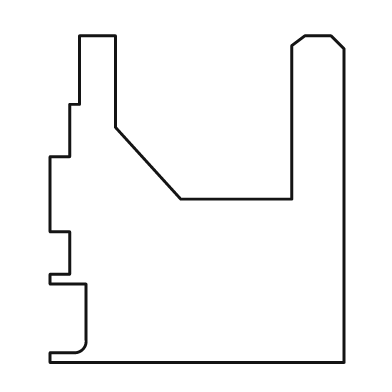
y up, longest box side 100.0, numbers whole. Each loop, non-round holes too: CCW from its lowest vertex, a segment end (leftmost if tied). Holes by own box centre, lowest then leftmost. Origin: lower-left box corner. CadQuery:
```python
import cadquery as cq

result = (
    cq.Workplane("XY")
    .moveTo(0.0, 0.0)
    .lineTo(90.0, 0.0)
    .lineTo(90.0, 96.0)
    .lineTo(86.0, 100.0)
    .lineTo(78.0, 100.0)
    .lineTo(74.0, 97.0)
    .lineTo(74.0, 50.0)
    .lineTo(40.0, 50.0)
    .lineTo(20.0, 72.0)
    .lineTo(20.0, 100.0)
    .lineTo(9.0, 100.0)
    .lineTo(9.0, 79.0)
    .lineTo(6.0, 79.0)
    .lineTo(6.0, 63.0)
    .lineTo(0.0, 63.0)
    .lineTo(0.0, 40.0)
    .lineTo(6.0, 40.0)
    .lineTo(6.0, 27.0)
    .lineTo(0.0, 27.0)
    .lineTo(0.0, 24.0)
    .lineTo(11.0, 24.0)
    .lineTo(11.0, 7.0)
    .threePointArc((10.0, 4.0), (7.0, 3.0))
    .lineTo(0.0, 3.0)
    .close()
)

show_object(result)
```